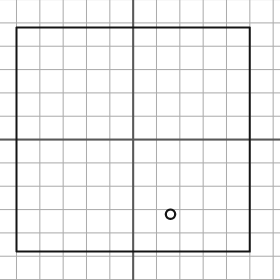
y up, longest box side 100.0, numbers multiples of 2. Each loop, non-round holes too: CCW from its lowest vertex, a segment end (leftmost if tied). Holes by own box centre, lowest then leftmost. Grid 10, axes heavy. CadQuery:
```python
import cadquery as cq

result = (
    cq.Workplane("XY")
    .moveTo(-50.0, -48.0)
    .lineTo(50.0, -48.0)
    .lineTo(50.0, 48.0)
    .lineTo(-50.0, 48.0)
    .close()
    .moveTo(16.0, -32.0)
    .circle(2.0)
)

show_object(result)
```